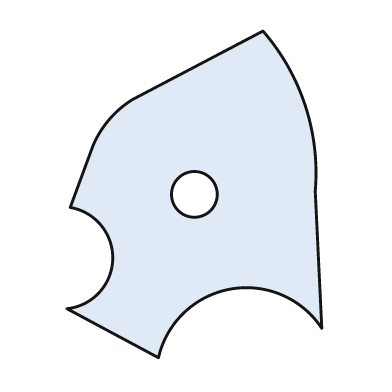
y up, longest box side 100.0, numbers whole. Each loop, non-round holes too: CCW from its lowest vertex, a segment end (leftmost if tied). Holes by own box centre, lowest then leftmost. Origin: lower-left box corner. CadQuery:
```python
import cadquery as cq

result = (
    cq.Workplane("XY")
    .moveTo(28.0, 0.0)
    .threePointArc((50.0, 21.0), (78.0, 9.0))
    .lineTo(76.0, 51.0)
    .threePointArc((73.0, 77.0), (60.0, 100.0))
    .lineTo(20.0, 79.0)
    .threePointArc((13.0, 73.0), (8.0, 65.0))
    .lineTo(1.0, 46.0)
    .threePointArc((14.0, 30.0), (0.0, 15.0))
    .close()
    .moveTo(39.0, 50.0)
    .circle(7.0)
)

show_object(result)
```